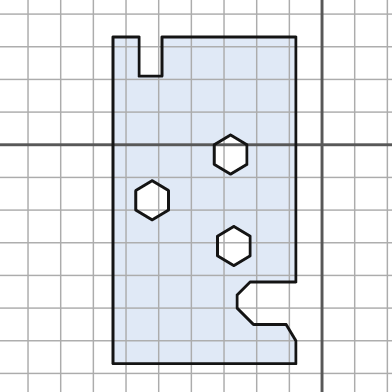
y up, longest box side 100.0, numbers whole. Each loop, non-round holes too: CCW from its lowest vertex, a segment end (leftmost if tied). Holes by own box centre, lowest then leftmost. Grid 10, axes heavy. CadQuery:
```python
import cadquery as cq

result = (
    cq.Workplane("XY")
    .moveTo(-64.0, -67.0)
    .lineTo(-8.0, -67.0)
    .lineTo(-8.0, -60.0)
    .lineTo(-11.0, -55.0)
    .lineTo(-21.0, -55.0)
    .lineTo(-26.0, -50.0)
    .lineTo(-26.0, -46.0)
    .lineTo(-22.0, -42.0)
    .lineTo(-8.0, -42.0)
    .lineTo(-8.0, 33.0)
    .lineTo(-49.0, 33.0)
    .lineTo(-49.0, 21.0)
    .lineTo(-56.0, 21.0)
    .lineTo(-56.0, 33.0)
    .lineTo(-64.0, 33.0)
    .close()
    .moveTo(-27.0, -37.0)
    .lineTo(-22.0, -34.0)
    .lineTo(-22.0, -28.0)
    .lineTo(-27.0, -25.0)
    .lineTo(-32.0, -28.0)
    .lineTo(-32.0, -34.0)
    .close()
    .moveTo(-52.0, -23.0)
    .lineTo(-47.0, -20.0)
    .lineTo(-47.0, -14.0)
    .lineTo(-52.0, -11.0)
    .lineTo(-57.0, -14.0)
    .lineTo(-57.0, -20.0)
    .close()
    .moveTo(-28.0, -9.0)
    .lineTo(-23.0, -6.0)
    .lineTo(-23.0, 0.0)
    .lineTo(-28.0, 3.0)
    .lineTo(-33.0, 0.0)
    .lineTo(-33.0, -6.0)
    .close()
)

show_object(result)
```